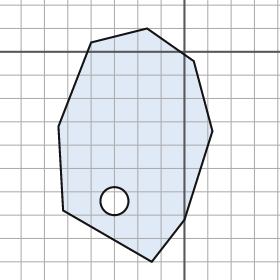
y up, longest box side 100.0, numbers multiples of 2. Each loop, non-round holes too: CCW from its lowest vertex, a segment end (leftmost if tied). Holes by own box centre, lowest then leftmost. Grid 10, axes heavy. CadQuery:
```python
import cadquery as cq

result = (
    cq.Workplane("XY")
    .moveTo(-14.0, -90.0)
    .lineTo(0.0, -72.0)
    .lineTo(12.0, -34.0)
    .lineTo(4.0, -4.0)
    .lineTo(-16.0, 10.0)
    .lineTo(-40.0, 4.0)
    .lineTo(-54.0, -32.0)
    .lineTo(-52.0, -68.0)
    .close()
    .moveTo(-30.0, -64.0)
    .circle(6.0)
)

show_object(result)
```